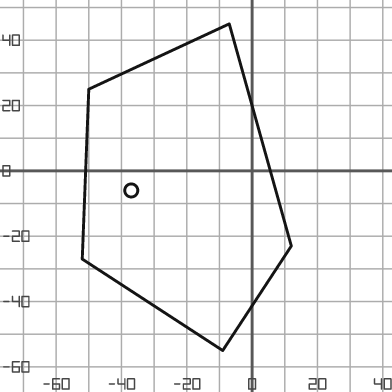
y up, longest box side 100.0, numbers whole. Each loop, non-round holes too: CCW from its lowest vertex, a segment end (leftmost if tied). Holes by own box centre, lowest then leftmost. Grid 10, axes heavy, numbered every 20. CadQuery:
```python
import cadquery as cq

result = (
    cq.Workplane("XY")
    .moveTo(-9.0, -55.0)
    .lineTo(12.0, -23.0)
    .lineTo(-7.0, 45.0)
    .lineTo(-50.0, 25.0)
    .lineTo(-52.0, -27.0)
    .close()
    .moveTo(-37.0, -6.0)
    .circle(2.0)
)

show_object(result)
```